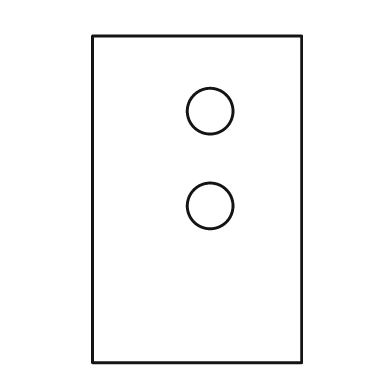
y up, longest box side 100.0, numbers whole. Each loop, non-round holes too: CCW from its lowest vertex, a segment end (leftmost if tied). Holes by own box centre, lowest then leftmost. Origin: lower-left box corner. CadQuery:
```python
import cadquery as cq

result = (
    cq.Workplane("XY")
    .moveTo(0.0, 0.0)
    .lineTo(64.0, 0.0)
    .lineTo(64.0, 100.0)
    .lineTo(0.0, 100.0)
    .close()
    .moveTo(36.0, 48.0)
    .circle(7.0)
    .moveTo(36.0, 77.0)
    .circle(7.0)
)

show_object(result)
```